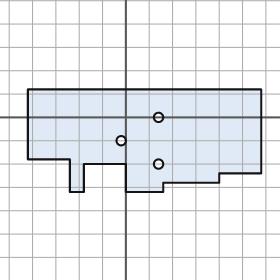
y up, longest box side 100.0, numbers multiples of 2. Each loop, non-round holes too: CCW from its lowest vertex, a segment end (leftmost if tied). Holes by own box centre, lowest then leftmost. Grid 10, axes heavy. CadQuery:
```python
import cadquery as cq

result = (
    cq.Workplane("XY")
    .moveTo(-24.0, -32.0)
    .lineTo(-18.0, -32.0)
    .lineTo(-18.0, -20.0)
    .lineTo(0.0, -20.0)
    .lineTo(0.0, -32.0)
    .lineTo(16.0, -32.0)
    .lineTo(16.0, -28.0)
    .lineTo(40.0, -28.0)
    .lineTo(40.0, -24.0)
    .lineTo(58.0, -24.0)
    .lineTo(58.0, 12.0)
    .lineTo(-42.0, 12.0)
    .lineTo(-42.0, -18.0)
    .lineTo(-24.0, -18.0)
    .close()
    .moveTo(14.0, -20.0)
    .circle(2.0)
    .moveTo(-2.0, -10.0)
    .circle(2.0)
    .moveTo(14.0, 0.0)
    .circle(2.0)
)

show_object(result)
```